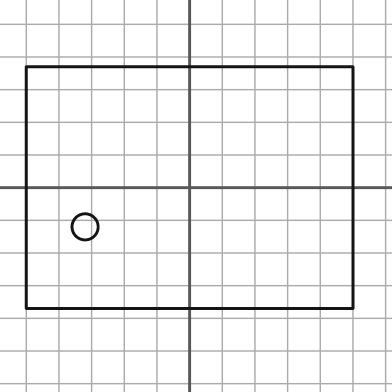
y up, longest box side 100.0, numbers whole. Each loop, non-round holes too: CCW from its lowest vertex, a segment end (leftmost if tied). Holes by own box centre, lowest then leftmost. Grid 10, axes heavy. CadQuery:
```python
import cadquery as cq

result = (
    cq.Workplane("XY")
    .moveTo(-50.0, -37.0)
    .lineTo(50.0, -37.0)
    .lineTo(50.0, 37.0)
    .lineTo(-50.0, 37.0)
    .close()
    .moveTo(-32.0, -12.0)
    .circle(4.0)
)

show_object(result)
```